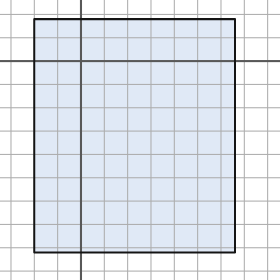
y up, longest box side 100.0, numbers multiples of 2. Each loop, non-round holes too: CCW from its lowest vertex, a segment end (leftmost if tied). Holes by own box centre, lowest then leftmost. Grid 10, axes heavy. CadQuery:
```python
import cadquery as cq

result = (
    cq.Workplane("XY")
    .moveTo(-20.0, -82.0)
    .lineTo(66.0, -82.0)
    .lineTo(66.0, 18.0)
    .lineTo(-20.0, 18.0)
    .close()
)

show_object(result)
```